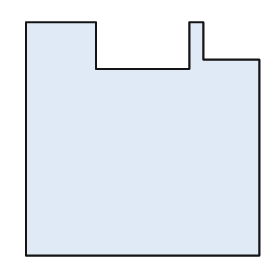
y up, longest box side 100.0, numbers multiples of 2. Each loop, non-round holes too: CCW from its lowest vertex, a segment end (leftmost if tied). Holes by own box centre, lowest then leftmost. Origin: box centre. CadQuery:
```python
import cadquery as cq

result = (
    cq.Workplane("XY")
    .moveTo(-50.0, -50.0)
    .lineTo(50.0, -50.0)
    .lineTo(50.0, 34.0)
    .lineTo(26.0, 34.0)
    .lineTo(26.0, 50.0)
    .lineTo(20.0, 50.0)
    .lineTo(20.0, 30.0)
    .lineTo(-20.0, 30.0)
    .lineTo(-20.0, 50.0)
    .lineTo(-50.0, 50.0)
    .close()
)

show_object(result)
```